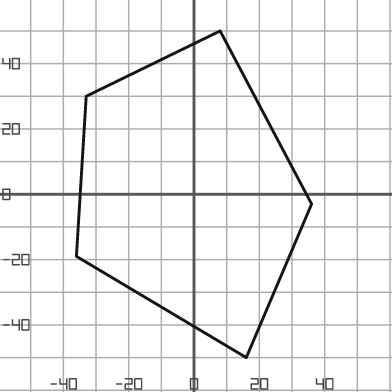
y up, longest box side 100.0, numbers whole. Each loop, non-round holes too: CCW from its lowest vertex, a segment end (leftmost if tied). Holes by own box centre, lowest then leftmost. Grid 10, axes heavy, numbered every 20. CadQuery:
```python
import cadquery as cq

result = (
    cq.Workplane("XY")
    .moveTo(16.0, -50.0)
    .lineTo(36.0, -3.0)
    .lineTo(8.0, 50.0)
    .lineTo(-33.0, 30.0)
    .lineTo(-36.0, -19.0)
    .close()
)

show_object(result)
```